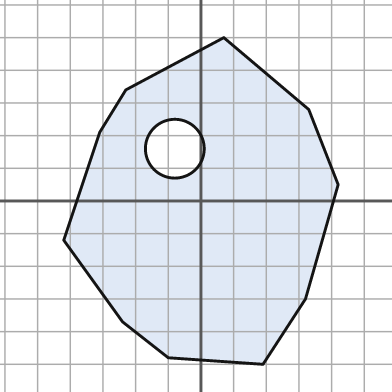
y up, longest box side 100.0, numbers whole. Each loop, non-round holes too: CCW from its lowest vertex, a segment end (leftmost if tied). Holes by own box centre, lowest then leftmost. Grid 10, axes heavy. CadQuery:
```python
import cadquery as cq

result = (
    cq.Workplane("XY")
    .moveTo(19.0, -50.0)
    .lineTo(32.0, -30.0)
    .lineTo(42.0, 5.0)
    .lineTo(33.0, 28.0)
    .lineTo(7.0, 50.0)
    .lineTo(-23.0, 34.0)
    .lineTo(-31.0, 21.0)
    .lineTo(-42.0, -12.0)
    .lineTo(-24.0, -37.0)
    .lineTo(-10.0, -48.0)
    .close()
    .moveTo(-8.0, 16.0)
    .circle(9.0)
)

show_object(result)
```